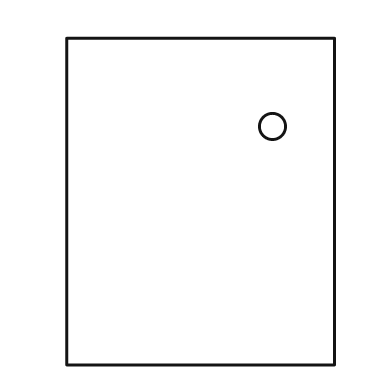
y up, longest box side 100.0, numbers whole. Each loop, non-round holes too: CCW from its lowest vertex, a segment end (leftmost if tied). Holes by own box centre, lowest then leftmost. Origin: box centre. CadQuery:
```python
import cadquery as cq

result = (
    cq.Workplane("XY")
    .moveTo(-41.0, -50.0)
    .lineTo(41.0, -50.0)
    .lineTo(41.0, 50.0)
    .lineTo(-41.0, 50.0)
    .close()
    .moveTo(22.0, 23.0)
    .circle(4.0)
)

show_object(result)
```